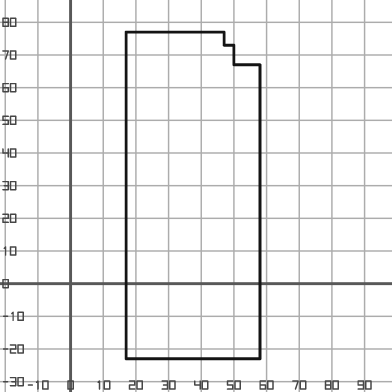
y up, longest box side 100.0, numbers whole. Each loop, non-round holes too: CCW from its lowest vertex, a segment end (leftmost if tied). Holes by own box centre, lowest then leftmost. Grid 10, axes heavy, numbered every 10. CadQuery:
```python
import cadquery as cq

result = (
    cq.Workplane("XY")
    .moveTo(17.0, -23.0)
    .lineTo(58.0, -23.0)
    .lineTo(58.0, 67.0)
    .lineTo(50.0, 67.0)
    .lineTo(50.0, 73.0)
    .lineTo(47.0, 73.0)
    .lineTo(47.0, 77.0)
    .lineTo(17.0, 77.0)
    .close()
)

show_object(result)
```